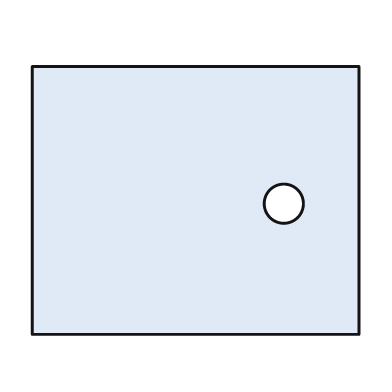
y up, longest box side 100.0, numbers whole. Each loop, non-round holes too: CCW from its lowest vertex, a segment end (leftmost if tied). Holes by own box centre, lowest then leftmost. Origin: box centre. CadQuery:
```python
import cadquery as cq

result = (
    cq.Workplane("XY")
    .moveTo(-50.0, -41.0)
    .lineTo(50.0, -41.0)
    .lineTo(50.0, 41.0)
    .lineTo(-50.0, 41.0)
    .close()
    .moveTo(27.0, -1.0)
    .circle(6.0)
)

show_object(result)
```